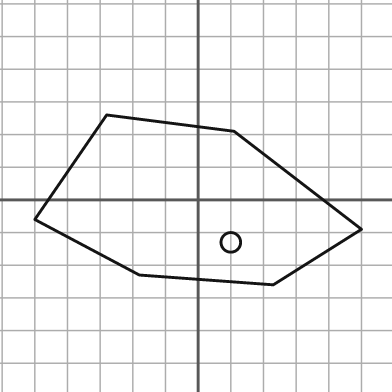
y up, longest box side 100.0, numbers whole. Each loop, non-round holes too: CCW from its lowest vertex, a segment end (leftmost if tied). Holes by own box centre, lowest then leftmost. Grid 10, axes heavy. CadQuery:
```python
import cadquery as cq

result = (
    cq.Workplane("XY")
    .moveTo(23.0, -26.0)
    .lineTo(50.0, -9.0)
    .lineTo(11.0, 21.0)
    .lineTo(-28.0, 26.0)
    .lineTo(-50.0, -6.0)
    .lineTo(-18.0, -23.0)
    .close()
    .moveTo(10.0, -13.0)
    .circle(3.0)
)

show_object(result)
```